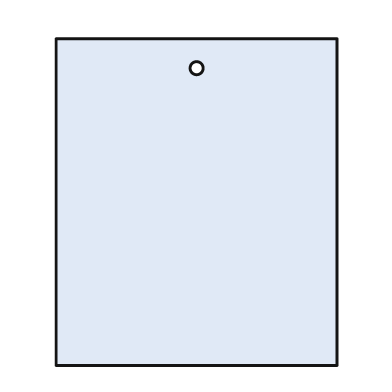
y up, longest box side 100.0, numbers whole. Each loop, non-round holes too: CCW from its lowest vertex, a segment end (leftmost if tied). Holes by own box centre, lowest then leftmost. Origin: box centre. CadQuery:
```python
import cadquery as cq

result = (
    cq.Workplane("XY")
    .moveTo(-43.0, -50.0)
    .lineTo(43.0, -50.0)
    .lineTo(43.0, 50.0)
    .lineTo(-43.0, 50.0)
    .close()
    .moveTo(0.0, 41.0)
    .circle(2.0)
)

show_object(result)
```